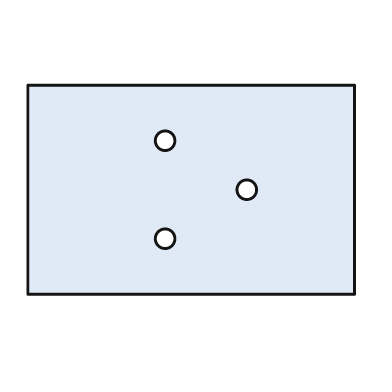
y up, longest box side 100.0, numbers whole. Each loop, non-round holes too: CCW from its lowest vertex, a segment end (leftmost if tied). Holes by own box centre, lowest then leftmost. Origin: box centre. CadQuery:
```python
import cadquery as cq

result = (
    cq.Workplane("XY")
    .moveTo(-50.0, -32.0)
    .lineTo(50.0, -32.0)
    .lineTo(50.0, 32.0)
    .lineTo(-50.0, 32.0)
    .close()
    .moveTo(-8.0, -15.0)
    .circle(3.0)
    .moveTo(17.0, 0.0)
    .circle(3.0)
    .moveTo(-8.0, 15.0)
    .circle(3.0)
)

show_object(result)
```